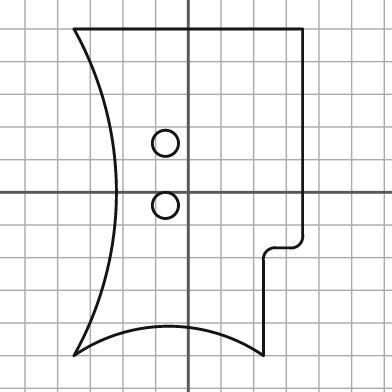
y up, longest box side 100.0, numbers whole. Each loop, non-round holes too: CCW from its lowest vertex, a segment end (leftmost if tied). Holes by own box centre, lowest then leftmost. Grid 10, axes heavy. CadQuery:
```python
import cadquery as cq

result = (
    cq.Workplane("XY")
    .moveTo(-35.0, -50.0)
    .threePointArc((-6.0, -41.0), (23.0, -50.0))
    .lineTo(23.0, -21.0)
    .threePointArc((24.0, -18.0), (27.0, -17.0))
    .lineTo(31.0, -17.0)
    .threePointArc((34.0, -16.0), (35.0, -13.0))
    .lineTo(35.0, 50.0)
    .lineTo(-35.0, 50.0)
    .threePointArc((-22.0, 0.0), (-35.0, -50.0))
    .close()
    .moveTo(-7.0, -4.0)
    .circle(4.0)
    .moveTo(-7.0, 15.0)
    .circle(4.0)
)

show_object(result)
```